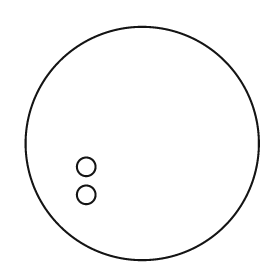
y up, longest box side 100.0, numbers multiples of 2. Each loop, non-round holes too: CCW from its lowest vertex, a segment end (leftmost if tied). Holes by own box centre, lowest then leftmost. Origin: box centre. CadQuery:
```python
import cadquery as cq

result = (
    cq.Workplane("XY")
    .moveTo(0.0, 0.0)
    .circle(50.0)
    .moveTo(-24.0, -22.0)
    .circle(4.0)
    .moveTo(-24.0, -10.0)
    .circle(4.0)
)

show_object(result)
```